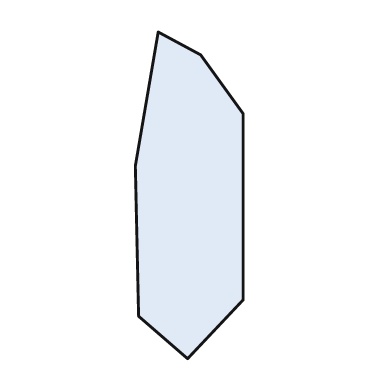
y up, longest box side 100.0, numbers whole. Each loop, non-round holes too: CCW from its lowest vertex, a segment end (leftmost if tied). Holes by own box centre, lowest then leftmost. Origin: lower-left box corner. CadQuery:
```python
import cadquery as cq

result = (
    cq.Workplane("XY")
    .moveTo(16.0, 0.0)
    .lineTo(33.0, 18.0)
    .lineTo(33.0, 75.0)
    .lineTo(20.0, 93.0)
    .lineTo(7.0, 100.0)
    .lineTo(0.0, 59.0)
    .lineTo(1.0, 13.0)
    .close()
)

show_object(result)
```